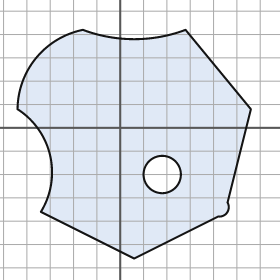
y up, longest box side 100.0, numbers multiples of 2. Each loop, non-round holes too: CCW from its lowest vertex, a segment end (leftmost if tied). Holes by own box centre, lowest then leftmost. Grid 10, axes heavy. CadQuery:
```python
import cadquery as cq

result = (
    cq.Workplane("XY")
    .moveTo(6.0, -56.0)
    .lineTo(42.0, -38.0)
    .threePointArc((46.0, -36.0), (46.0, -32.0))
    .lineTo(56.0, 8.0)
    .lineTo(28.0, 42.0)
    .threePointArc((6.0, 38.0), (-16.0, 42.0))
    .threePointArc((-36.0, 30.0), (-44.0, 8.0))
    .threePointArc((-30.0, -12.0), (-34.0, -36.0))
    .close()
    .moveTo(18.0, -20.0)
    .circle(8.0)
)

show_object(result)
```